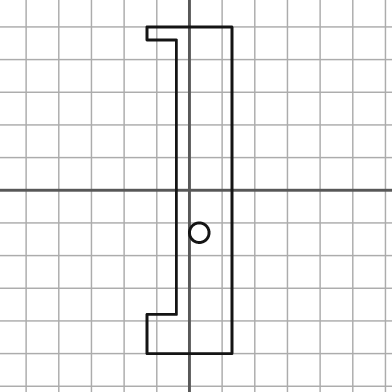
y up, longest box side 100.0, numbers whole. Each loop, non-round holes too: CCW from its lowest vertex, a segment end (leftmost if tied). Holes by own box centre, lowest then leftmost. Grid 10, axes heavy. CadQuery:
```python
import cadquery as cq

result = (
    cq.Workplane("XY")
    .moveTo(-13.0, -50.0)
    .lineTo(13.0, -50.0)
    .lineTo(13.0, 50.0)
    .lineTo(-13.0, 50.0)
    .lineTo(-13.0, 46.0)
    .lineTo(-4.0, 46.0)
    .lineTo(-4.0, -38.0)
    .lineTo(-13.0, -38.0)
    .close()
    .moveTo(3.0, -13.0)
    .circle(3.0)
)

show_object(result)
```